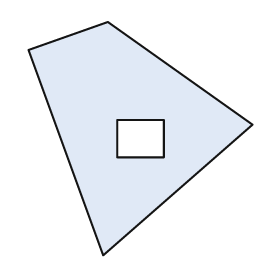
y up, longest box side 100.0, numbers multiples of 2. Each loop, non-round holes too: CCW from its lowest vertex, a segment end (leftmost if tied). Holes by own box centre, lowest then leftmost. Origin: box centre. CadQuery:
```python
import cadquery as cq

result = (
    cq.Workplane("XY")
    .moveTo(-16.0, -50.0)
    .lineTo(48.0, 6.0)
    .lineTo(-14.0, 50.0)
    .lineTo(-48.0, 38.0)
    .close()
    .moveTo(-10.0, -8.0)
    .lineTo(10.0, -8.0)
    .lineTo(10.0, 8.0)
    .lineTo(-10.0, 8.0)
    .close()
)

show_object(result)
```